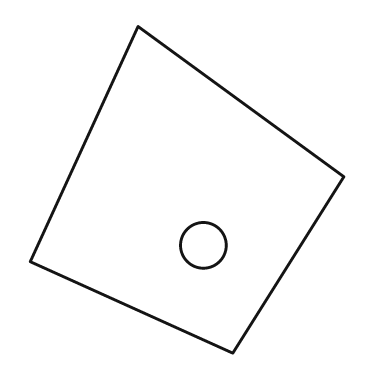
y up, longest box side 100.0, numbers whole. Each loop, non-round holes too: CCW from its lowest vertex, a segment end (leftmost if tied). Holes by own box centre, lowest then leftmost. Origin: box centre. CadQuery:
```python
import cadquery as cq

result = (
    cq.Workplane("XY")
    .moveTo(14.0, -50.0)
    .lineTo(48.0, 4.0)
    .lineTo(-15.0, 50.0)
    .lineTo(-48.0, -22.0)
    .close()
    .moveTo(5.0, -17.0)
    .circle(7.0)
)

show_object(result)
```